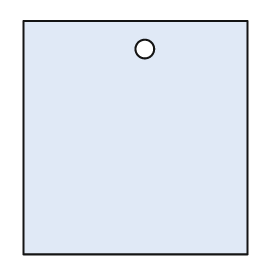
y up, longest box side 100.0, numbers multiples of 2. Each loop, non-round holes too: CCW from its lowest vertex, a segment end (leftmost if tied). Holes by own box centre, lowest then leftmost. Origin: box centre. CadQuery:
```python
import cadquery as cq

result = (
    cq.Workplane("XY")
    .moveTo(-48.0, -50.0)
    .lineTo(48.0, -50.0)
    .lineTo(48.0, 50.0)
    .lineTo(-48.0, 50.0)
    .close()
    .moveTo(4.0, 38.0)
    .circle(4.0)
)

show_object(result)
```